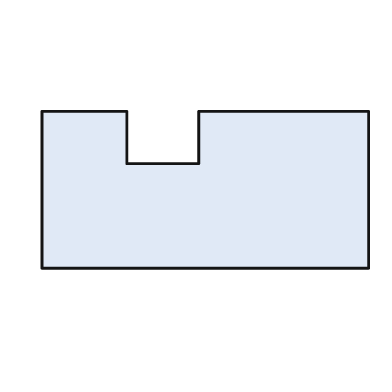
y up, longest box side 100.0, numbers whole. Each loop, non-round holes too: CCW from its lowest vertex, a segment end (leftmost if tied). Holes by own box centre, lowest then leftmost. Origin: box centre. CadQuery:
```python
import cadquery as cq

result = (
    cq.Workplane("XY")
    .moveTo(-50.0, -24.0)
    .lineTo(50.0, -24.0)
    .lineTo(50.0, 24.0)
    .lineTo(-2.0, 24.0)
    .lineTo(-2.0, 8.0)
    .lineTo(-24.0, 8.0)
    .lineTo(-24.0, 24.0)
    .lineTo(-50.0, 24.0)
    .close()
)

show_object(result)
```